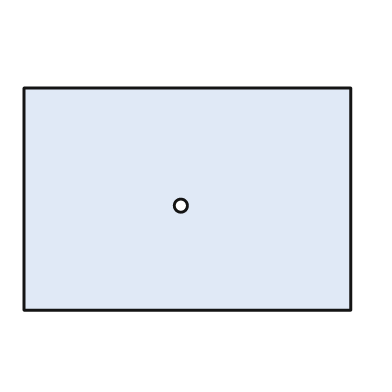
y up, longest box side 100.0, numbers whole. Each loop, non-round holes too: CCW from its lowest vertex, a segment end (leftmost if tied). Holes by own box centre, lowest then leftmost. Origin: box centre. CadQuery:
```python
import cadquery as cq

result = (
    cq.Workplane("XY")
    .moveTo(-50.0, -34.0)
    .lineTo(50.0, -34.0)
    .lineTo(50.0, 34.0)
    .lineTo(-50.0, 34.0)
    .close()
    .moveTo(-2.0, -2.0)
    .circle(2.0)
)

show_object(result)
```